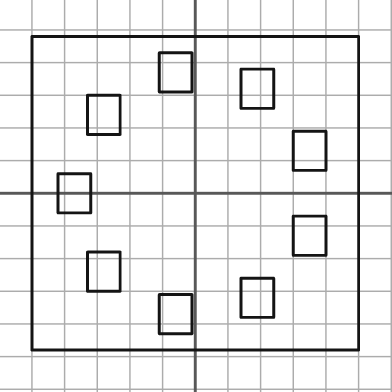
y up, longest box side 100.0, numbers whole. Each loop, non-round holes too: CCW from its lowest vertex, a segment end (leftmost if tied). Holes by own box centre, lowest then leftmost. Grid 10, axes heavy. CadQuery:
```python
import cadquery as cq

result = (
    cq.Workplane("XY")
    .moveTo(-50.0, -48.0)
    .lineTo(50.0, -48.0)
    .lineTo(50.0, 48.0)
    .lineTo(-50.0, 48.0)
    .close()
    .moveTo(-11.0, -43.0)
    .lineTo(-1.0, -43.0)
    .lineTo(-1.0, -31.0)
    .lineTo(-11.0, -31.0)
    .close()
    .moveTo(14.0, -38.0)
    .lineTo(24.0, -38.0)
    .lineTo(24.0, -26.0)
    .lineTo(14.0, -26.0)
    .close()
    .moveTo(-33.0, -30.0)
    .lineTo(-23.0, -30.0)
    .lineTo(-23.0, -18.0)
    .lineTo(-33.0, -18.0)
    .close()
    .moveTo(30.0, -19.0)
    .lineTo(40.0, -19.0)
    .lineTo(40.0, -7.0)
    .lineTo(30.0, -7.0)
    .close()
    .moveTo(-42.0, -6.0)
    .lineTo(-32.0, -6.0)
    .lineTo(-32.0, 6.0)
    .lineTo(-42.0, 6.0)
    .close()
    .moveTo(30.0, 7.0)
    .lineTo(40.0, 7.0)
    .lineTo(40.0, 19.0)
    .lineTo(30.0, 19.0)
    .close()
    .moveTo(-33.0, 18.0)
    .lineTo(-23.0, 18.0)
    .lineTo(-23.0, 30.0)
    .lineTo(-33.0, 30.0)
    .close()
    .moveTo(14.0, 26.0)
    .lineTo(24.0, 26.0)
    .lineTo(24.0, 38.0)
    .lineTo(14.0, 38.0)
    .close()
    .moveTo(-11.0, 31.0)
    .lineTo(-1.0, 31.0)
    .lineTo(-1.0, 43.0)
    .lineTo(-11.0, 43.0)
    .close()
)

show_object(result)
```